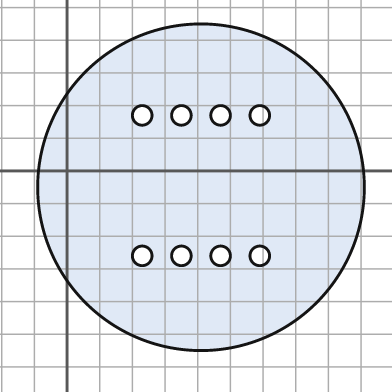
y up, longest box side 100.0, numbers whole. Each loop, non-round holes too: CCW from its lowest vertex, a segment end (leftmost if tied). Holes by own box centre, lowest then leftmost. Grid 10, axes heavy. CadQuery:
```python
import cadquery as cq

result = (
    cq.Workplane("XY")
    .moveTo(41.0, -5.0)
    .circle(50.0)
    .moveTo(23.0, -26.0)
    .circle(3.0)
    .moveTo(35.0, -26.0)
    .circle(3.0)
    .moveTo(47.0, -26.0)
    .circle(3.0)
    .moveTo(59.0, -26.0)
    .circle(3.0)
    .moveTo(23.0, 17.0)
    .circle(3.0)
    .moveTo(35.0, 17.0)
    .circle(3.0)
    .moveTo(47.0, 17.0)
    .circle(3.0)
    .moveTo(59.0, 17.0)
    .circle(3.0)
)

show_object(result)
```